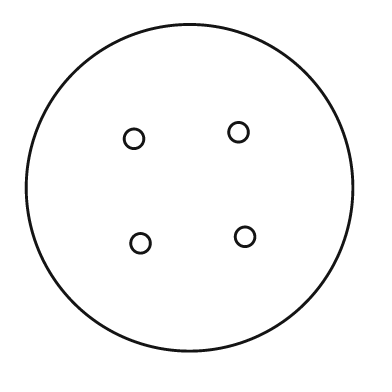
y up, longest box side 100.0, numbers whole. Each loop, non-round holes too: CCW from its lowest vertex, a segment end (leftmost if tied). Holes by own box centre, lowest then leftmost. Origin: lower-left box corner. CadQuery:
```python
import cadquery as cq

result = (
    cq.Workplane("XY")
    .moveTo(50.0, 50.0)
    .circle(50.0)
    .moveTo(35.0, 33.0)
    .circle(3.0)
    .moveTo(67.0, 35.0)
    .circle(3.0)
    .moveTo(33.0, 65.0)
    .circle(3.0)
    .moveTo(65.0, 67.0)
    .circle(3.0)
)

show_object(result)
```